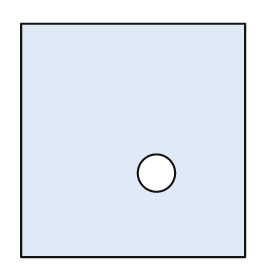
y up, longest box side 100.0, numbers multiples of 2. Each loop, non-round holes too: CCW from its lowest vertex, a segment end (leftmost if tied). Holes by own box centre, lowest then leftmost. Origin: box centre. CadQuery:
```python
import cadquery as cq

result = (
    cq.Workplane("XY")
    .moveTo(-48.0, -50.0)
    .lineTo(48.0, -50.0)
    .lineTo(48.0, 50.0)
    .lineTo(-48.0, 50.0)
    .close()
    .moveTo(10.0, -14.0)
    .circle(8.0)
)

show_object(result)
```